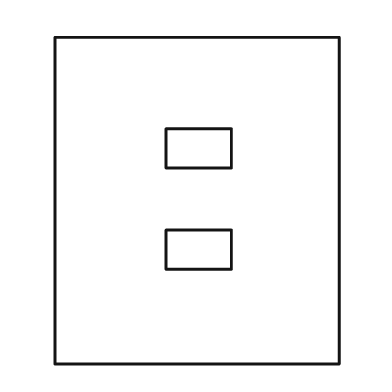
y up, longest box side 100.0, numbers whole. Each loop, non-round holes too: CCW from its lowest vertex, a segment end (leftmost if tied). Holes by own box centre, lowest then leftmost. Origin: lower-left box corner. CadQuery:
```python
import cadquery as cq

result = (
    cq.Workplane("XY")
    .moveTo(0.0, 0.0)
    .lineTo(87.0, 0.0)
    .lineTo(87.0, 100.0)
    .lineTo(0.0, 100.0)
    .close()
    .moveTo(34.0, 29.0)
    .lineTo(54.0, 29.0)
    .lineTo(54.0, 41.0)
    .lineTo(34.0, 41.0)
    .close()
    .moveTo(34.0, 60.0)
    .lineTo(54.0, 60.0)
    .lineTo(54.0, 72.0)
    .lineTo(34.0, 72.0)
    .close()
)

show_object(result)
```